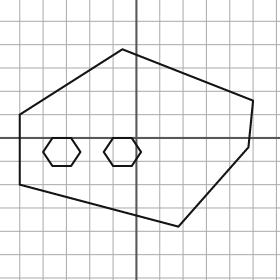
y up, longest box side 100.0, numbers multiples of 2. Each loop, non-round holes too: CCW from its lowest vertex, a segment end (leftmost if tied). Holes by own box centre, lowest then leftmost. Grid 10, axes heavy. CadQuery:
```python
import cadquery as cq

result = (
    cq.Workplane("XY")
    .moveTo(18.0, -38.0)
    .lineTo(48.0, -4.0)
    .lineTo(50.0, 16.0)
    .lineTo(-6.0, 38.0)
    .lineTo(-50.0, 10.0)
    .lineTo(-50.0, -20.0)
    .close()
    .moveTo(-36.0, -12.0)
    .lineTo(-28.0, -12.0)
    .lineTo(-24.0, -6.0)
    .lineTo(-28.0, 0.0)
    .lineTo(-36.0, 0.0)
    .lineTo(-40.0, -6.0)
    .close()
    .moveTo(-10.0, -12.0)
    .lineTo(-2.0, -12.0)
    .lineTo(2.0, -6.0)
    .lineTo(-2.0, 0.0)
    .lineTo(-10.0, 0.0)
    .lineTo(-14.0, -6.0)
    .close()
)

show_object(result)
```